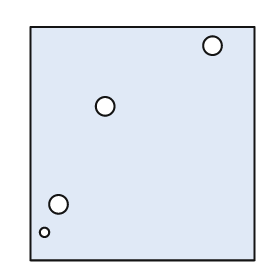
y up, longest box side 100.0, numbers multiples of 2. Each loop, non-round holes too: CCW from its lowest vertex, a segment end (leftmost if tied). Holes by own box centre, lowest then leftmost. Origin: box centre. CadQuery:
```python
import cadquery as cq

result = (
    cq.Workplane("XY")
    .moveTo(-48.0, -50.0)
    .lineTo(48.0, -50.0)
    .lineTo(48.0, 50.0)
    .lineTo(-48.0, 50.0)
    .close()
    .moveTo(-42.0, -38.0)
    .circle(2.0)
    .moveTo(-36.0, -26.0)
    .circle(4.0)
    .moveTo(-16.0, 16.0)
    .circle(4.0)
    .moveTo(30.0, 42.0)
    .circle(4.0)
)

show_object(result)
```